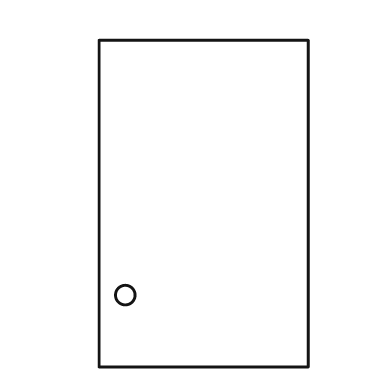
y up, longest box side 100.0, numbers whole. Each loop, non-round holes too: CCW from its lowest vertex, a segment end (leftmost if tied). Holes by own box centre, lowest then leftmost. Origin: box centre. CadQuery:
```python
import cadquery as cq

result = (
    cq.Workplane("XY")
    .moveTo(-32.0, -50.0)
    .lineTo(32.0, -50.0)
    .lineTo(32.0, 50.0)
    .lineTo(-32.0, 50.0)
    .close()
    .moveTo(-24.0, -28.0)
    .circle(3.0)
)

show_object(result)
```